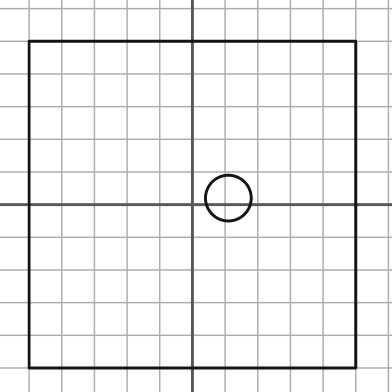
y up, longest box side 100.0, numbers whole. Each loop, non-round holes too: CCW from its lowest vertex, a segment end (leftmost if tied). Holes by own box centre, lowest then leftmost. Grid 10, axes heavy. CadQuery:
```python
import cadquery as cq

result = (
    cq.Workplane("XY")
    .moveTo(-50.0, -50.0)
    .lineTo(50.0, -50.0)
    .lineTo(50.0, 50.0)
    .lineTo(-50.0, 50.0)
    .close()
    .moveTo(11.0, 2.0)
    .circle(7.0)
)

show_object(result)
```